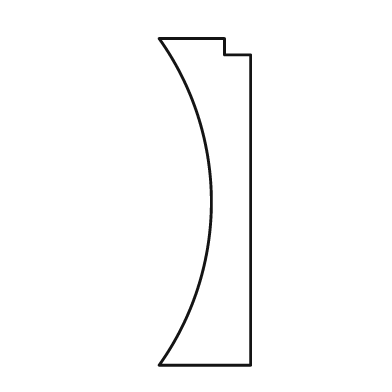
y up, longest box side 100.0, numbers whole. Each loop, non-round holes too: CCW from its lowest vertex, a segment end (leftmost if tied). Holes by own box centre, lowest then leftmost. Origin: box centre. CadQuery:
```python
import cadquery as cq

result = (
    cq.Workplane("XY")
    .moveTo(-14.0, -50.0)
    .lineTo(14.0, -50.0)
    .lineTo(14.0, 45.0)
    .lineTo(6.0, 45.0)
    .lineTo(6.0, 50.0)
    .lineTo(-14.0, 50.0)
    .threePointArc((2.0, 0.0), (-14.0, -50.0))
    .close()
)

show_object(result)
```